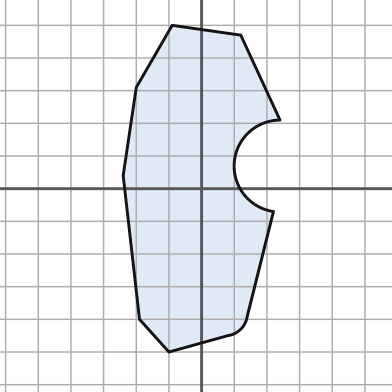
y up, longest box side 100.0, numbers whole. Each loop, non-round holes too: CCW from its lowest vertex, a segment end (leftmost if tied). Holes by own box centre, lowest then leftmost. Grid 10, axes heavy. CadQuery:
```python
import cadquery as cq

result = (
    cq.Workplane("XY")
    .moveTo(-10.0, -50.0)
    .lineTo(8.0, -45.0)
    .threePointArc((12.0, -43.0), (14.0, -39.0))
    .lineTo(22.0, -7.0)
    .threePointArc((10.0, 8.0), (24.0, 21.0))
    .lineTo(12.0, 47.0)
    .lineTo(-9.0, 50.0)
    .lineTo(-20.0, 31.0)
    .lineTo(-24.0, 4.0)
    .lineTo(-19.0, -40.0)
    .close()
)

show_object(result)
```